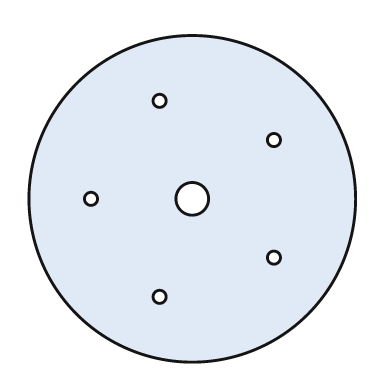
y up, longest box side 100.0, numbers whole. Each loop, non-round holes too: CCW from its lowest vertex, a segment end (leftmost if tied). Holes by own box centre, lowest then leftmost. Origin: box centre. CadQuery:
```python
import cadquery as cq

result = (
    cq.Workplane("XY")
    .moveTo(0.0, 0.0)
    .circle(50.0)
    .moveTo(-10.0, -30.0)
    .circle(2.0)
    .moveTo(25.0, -18.0)
    .circle(2.0)
    .moveTo(-31.0, 0.0)
    .circle(2.0)
    .moveTo(0.0, 0.0)
    .circle(5.0)
    .moveTo(25.0, 18.0)
    .circle(2.0)
    .moveTo(-10.0, 30.0)
    .circle(2.0)
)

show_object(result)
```